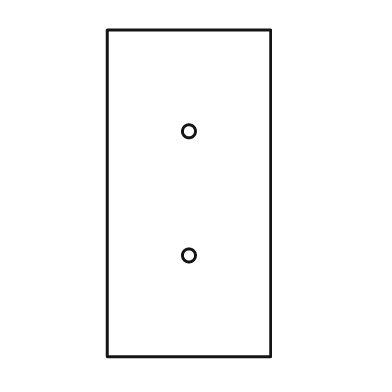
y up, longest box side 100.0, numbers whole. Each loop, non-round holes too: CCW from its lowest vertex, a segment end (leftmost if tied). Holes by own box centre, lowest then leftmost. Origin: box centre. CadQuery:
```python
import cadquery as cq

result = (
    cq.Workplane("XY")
    .moveTo(-25.0, -50.0)
    .lineTo(25.0, -50.0)
    .lineTo(25.0, 50.0)
    .lineTo(-25.0, 50.0)
    .close()
    .moveTo(0.0, -19.0)
    .circle(2.0)
    .moveTo(0.0, 19.0)
    .circle(2.0)
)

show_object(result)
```